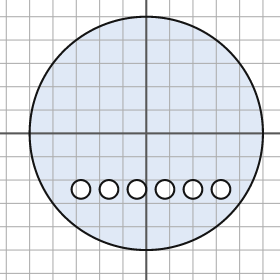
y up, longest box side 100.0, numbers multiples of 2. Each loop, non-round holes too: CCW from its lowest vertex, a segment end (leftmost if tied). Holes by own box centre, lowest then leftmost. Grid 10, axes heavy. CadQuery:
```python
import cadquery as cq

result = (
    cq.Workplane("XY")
    .moveTo(0.0, 0.0)
    .circle(50.0)
    .moveTo(-28.0, -24.0)
    .circle(4.0)
    .moveTo(-16.0, -24.0)
    .circle(4.0)
    .moveTo(-4.0, -24.0)
    .circle(4.0)
    .moveTo(8.0, -24.0)
    .circle(4.0)
    .moveTo(20.0, -24.0)
    .circle(4.0)
    .moveTo(32.0, -24.0)
    .circle(4.0)
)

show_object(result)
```